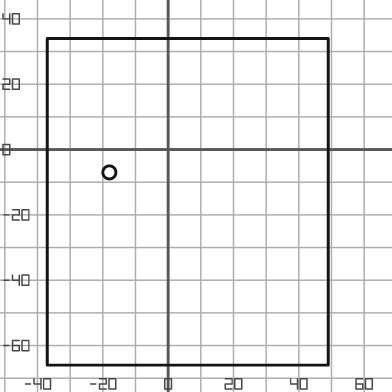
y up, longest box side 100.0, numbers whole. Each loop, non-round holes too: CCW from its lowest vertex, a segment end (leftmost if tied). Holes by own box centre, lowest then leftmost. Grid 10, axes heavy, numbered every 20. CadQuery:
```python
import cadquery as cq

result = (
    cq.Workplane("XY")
    .moveTo(-37.0, -66.0)
    .lineTo(49.0, -66.0)
    .lineTo(49.0, 34.0)
    .lineTo(-37.0, 34.0)
    .close()
    .moveTo(-18.0, -7.0)
    .circle(2.0)
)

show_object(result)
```